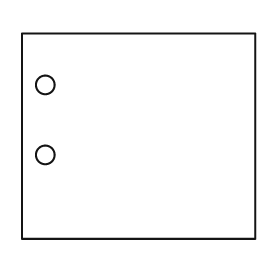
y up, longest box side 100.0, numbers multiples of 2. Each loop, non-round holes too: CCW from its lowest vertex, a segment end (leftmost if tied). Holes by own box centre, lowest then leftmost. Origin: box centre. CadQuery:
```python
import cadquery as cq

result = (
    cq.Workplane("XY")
    .moveTo(-50.0, -44.0)
    .lineTo(50.0, -44.0)
    .lineTo(50.0, 44.0)
    .lineTo(-50.0, 44.0)
    .close()
    .moveTo(-40.0, -8.0)
    .circle(4.0)
    .moveTo(-40.0, 22.0)
    .circle(4.0)
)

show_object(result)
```